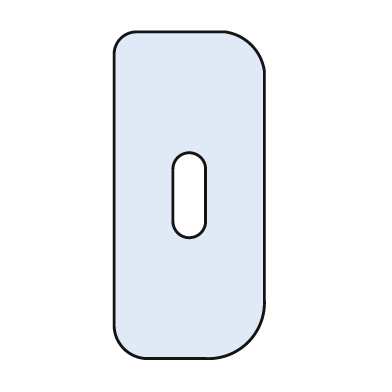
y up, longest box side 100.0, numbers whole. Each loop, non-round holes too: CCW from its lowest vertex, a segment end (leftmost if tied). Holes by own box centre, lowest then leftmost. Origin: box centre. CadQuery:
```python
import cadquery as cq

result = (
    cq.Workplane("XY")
    .moveTo(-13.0, -50.0)
    .lineTo(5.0, -50.0)
    .threePointArc((18.0, -45.0), (23.0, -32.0))
    .lineTo(23.0, 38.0)
    .threePointArc((19.0, 46.0), (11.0, 50.0))
    .lineTo(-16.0, 50.0)
    .threePointArc((-21.0, 48.0), (-23.0, 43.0))
    .lineTo(-23.0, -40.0)
    .threePointArc((-20.0, -47.0), (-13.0, -50.0))
    .close()
    .moveTo(-5.0, -8.0)
    .threePointArc((0.0, -13.0), (5.0, -8.0))
    .lineTo(5.0, 8.0)
    .threePointArc((0.0, 13.0), (-5.0, 8.0))
    .close()
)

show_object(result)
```